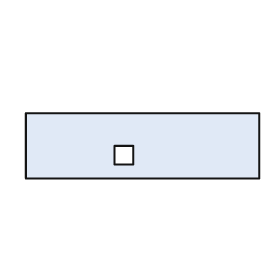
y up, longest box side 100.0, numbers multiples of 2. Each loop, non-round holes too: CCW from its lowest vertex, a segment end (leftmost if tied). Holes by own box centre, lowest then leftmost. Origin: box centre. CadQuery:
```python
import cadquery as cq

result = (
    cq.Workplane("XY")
    .moveTo(-50.0, -14.0)
    .lineTo(50.0, -14.0)
    .lineTo(50.0, 14.0)
    .lineTo(-50.0, 14.0)
    .close()
    .moveTo(-12.0, -8.0)
    .lineTo(-4.0, -8.0)
    .lineTo(-4.0, 0.0)
    .lineTo(-12.0, 0.0)
    .close()
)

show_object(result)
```